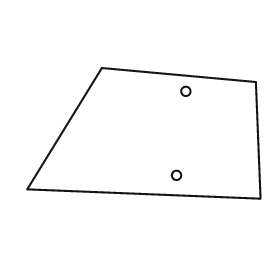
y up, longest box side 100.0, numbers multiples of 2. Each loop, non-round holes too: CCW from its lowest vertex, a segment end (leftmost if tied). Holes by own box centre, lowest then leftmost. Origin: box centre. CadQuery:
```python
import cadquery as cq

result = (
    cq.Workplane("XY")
    .moveTo(50.0, -28.0)
    .lineTo(48.0, 22.0)
    .lineTo(-18.0, 28.0)
    .lineTo(-50.0, -24.0)
    .close()
    .moveTo(14.0, -18.0)
    .circle(2.0)
    .moveTo(18.0, 18.0)
    .circle(2.0)
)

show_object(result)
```